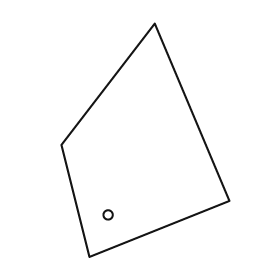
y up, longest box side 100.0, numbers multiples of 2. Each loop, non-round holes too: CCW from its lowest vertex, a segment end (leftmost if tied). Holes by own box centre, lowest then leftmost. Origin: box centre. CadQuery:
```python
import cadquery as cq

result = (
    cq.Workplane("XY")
    .moveTo(-24.0, -50.0)
    .lineTo(36.0, -26.0)
    .lineTo(4.0, 50.0)
    .lineTo(-36.0, -2.0)
    .close()
    .moveTo(-16.0, -32.0)
    .circle(2.0)
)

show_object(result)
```